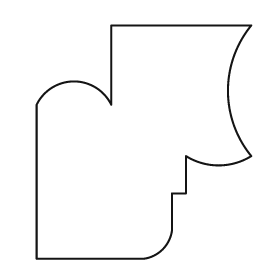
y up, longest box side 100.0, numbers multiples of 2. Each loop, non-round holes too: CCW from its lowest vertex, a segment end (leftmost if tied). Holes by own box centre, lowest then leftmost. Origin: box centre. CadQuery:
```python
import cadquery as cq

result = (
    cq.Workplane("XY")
    .moveTo(-46.0, -50.0)
    .lineTo(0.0, -50.0)
    .threePointArc((8.0, -46.0), (12.0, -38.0))
    .lineTo(12.0, -22.0)
    .lineTo(18.0, -22.0)
    .lineTo(18.0, -6.0)
    .threePointArc((32.0, -10.0), (46.0, -6.0))
    .threePointArc((36.0, 22.0), (46.0, 50.0))
    .lineTo(-14.0, 50.0)
    .lineTo(-14.0, 16.0)
    .threePointArc((-30.0, 26.0), (-46.0, 16.0))
    .close()
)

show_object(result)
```